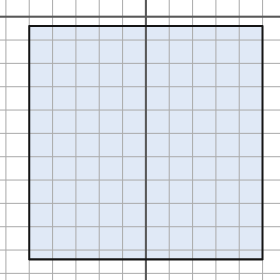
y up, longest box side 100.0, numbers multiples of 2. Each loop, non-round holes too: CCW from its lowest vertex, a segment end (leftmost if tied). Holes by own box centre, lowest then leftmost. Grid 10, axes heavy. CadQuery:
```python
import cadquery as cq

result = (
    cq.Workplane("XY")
    .moveTo(-50.0, -104.0)
    .lineTo(50.0, -104.0)
    .lineTo(50.0, -4.0)
    .lineTo(-50.0, -4.0)
    .close()
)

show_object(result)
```